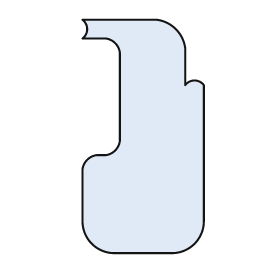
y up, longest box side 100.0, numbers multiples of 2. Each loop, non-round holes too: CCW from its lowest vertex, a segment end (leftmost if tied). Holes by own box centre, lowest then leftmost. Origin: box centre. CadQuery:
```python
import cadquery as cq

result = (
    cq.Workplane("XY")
    .moveTo(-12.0, -50.0)
    .lineTo(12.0, -50.0)
    .threePointArc((22.0, -46.0), (26.0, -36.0))
    .lineTo(26.0, 22.0)
    .threePointArc((22.0, 24.0), (18.0, 22.0))
    .lineTo(18.0, 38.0)
    .threePointArc((14.0, 46.0), (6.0, 50.0))
    .lineTo(-26.0, 50.0)
    .threePointArc((-24.0, 46.0), (-26.0, 42.0))
    .lineTo(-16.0, 42.0)
    .threePointArc((-12.0, 40.0), (-10.0, 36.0))
    .lineTo(-10.0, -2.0)
    .threePointArc((-12.0, -6.0), (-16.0, -8.0))
    .lineTo(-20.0, -8.0)
    .threePointArc((-24.0, -10.0), (-26.0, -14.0))
    .lineTo(-26.0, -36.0)
    .threePointArc((-22.0, -46.0), (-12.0, -50.0))
    .close()
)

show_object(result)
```